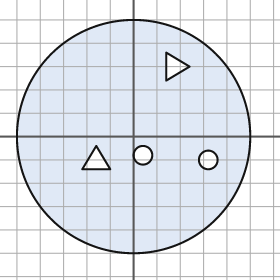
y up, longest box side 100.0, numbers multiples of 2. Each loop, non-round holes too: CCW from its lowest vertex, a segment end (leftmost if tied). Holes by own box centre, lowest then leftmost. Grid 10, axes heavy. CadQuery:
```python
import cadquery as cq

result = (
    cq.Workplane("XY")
    .moveTo(0.0, 0.0)
    .circle(50.0)
    .moveTo(32.0, -10.0)
    .circle(4.0)
    .moveTo(-22.0, -14.0)
    .lineTo(-10.0, -14.0)
    .lineTo(-16.0, -4.0)
    .close()
    .moveTo(4.0, -8.0)
    .circle(4.0)
    .moveTo(14.0, 24.0)
    .lineTo(24.0, 30.0)
    .lineTo(14.0, 36.0)
    .close()
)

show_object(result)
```